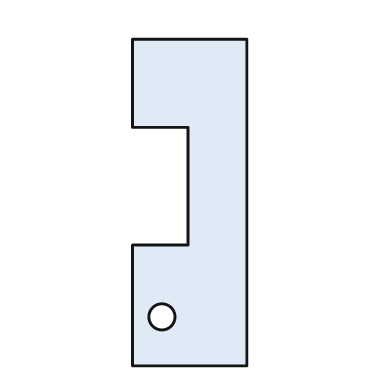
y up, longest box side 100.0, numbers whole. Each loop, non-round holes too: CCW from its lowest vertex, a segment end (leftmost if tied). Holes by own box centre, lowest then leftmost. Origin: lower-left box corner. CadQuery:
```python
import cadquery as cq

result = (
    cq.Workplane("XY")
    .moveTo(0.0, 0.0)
    .lineTo(35.0, 0.0)
    .lineTo(35.0, 100.0)
    .lineTo(0.0, 100.0)
    .lineTo(0.0, 73.0)
    .lineTo(17.0, 73.0)
    .lineTo(17.0, 37.0)
    .lineTo(0.0, 37.0)
    .close()
    .moveTo(9.0, 15.0)
    .circle(4.0)
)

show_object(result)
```